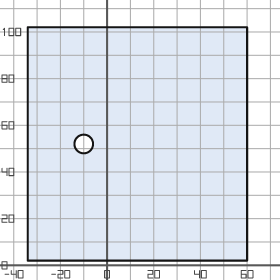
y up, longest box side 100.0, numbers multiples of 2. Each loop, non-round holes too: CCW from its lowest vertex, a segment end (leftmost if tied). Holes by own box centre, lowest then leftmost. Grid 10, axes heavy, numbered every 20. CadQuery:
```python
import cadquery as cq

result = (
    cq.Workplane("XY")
    .moveTo(-34.0, 2.0)
    .lineTo(60.0, 2.0)
    .lineTo(60.0, 102.0)
    .lineTo(-34.0, 102.0)
    .close()
    .moveTo(-10.0, 52.0)
    .circle(4.0)
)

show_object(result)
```